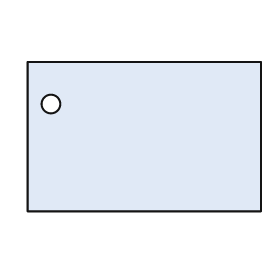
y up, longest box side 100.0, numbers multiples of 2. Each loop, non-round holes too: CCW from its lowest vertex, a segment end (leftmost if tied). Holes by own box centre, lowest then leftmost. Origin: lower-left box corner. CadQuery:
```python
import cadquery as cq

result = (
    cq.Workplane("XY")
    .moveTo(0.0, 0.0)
    .lineTo(100.0, 0.0)
    .lineTo(100.0, 64.0)
    .lineTo(0.0, 64.0)
    .close()
    .moveTo(10.0, 46.0)
    .circle(4.0)
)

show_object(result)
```